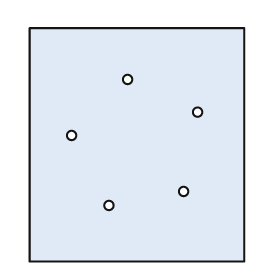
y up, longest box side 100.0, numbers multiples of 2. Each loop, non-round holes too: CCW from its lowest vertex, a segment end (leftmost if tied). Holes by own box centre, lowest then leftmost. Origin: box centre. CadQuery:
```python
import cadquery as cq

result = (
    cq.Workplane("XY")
    .moveTo(-46.0, -50.0)
    .lineTo(46.0, -50.0)
    .lineTo(46.0, 50.0)
    .lineTo(-46.0, 50.0)
    .close()
    .moveTo(-12.0, -26.0)
    .circle(2.0)
    .moveTo(20.0, -20.0)
    .circle(2.0)
    .moveTo(-28.0, 4.0)
    .circle(2.0)
    .moveTo(26.0, 14.0)
    .circle(2.0)
    .moveTo(-4.0, 28.0)
    .circle(2.0)
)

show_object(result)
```